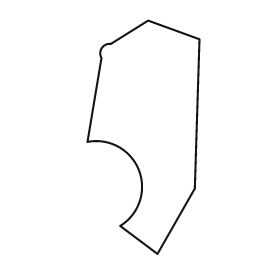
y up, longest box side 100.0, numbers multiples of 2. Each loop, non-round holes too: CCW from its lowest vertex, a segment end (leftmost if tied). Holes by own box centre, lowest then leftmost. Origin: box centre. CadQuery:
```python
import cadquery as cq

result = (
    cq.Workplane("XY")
    .moveTo(6.0, -50.0)
    .lineTo(22.0, -22.0)
    .lineTo(24.0, 42.0)
    .lineTo(2.0, 50.0)
    .lineTo(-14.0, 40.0)
    .threePointArc((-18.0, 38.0), (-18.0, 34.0))
    .lineTo(-24.0, -2.0)
    .threePointArc((-2.0, -14.0), (-10.0, -38.0))
    .close()
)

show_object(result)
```